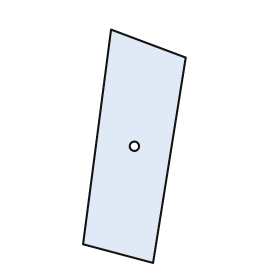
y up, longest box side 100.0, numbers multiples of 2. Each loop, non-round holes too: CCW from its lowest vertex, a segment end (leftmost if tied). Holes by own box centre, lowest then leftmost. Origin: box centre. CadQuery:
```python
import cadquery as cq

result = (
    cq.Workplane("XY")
    .moveTo(8.0, -50.0)
    .lineTo(22.0, 38.0)
    .lineTo(-10.0, 50.0)
    .lineTo(-22.0, -42.0)
    .close()
    .moveTo(0.0, 0.0)
    .circle(2.0)
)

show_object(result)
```